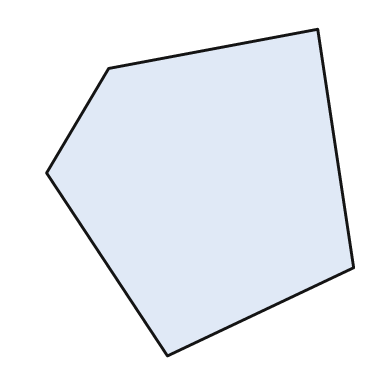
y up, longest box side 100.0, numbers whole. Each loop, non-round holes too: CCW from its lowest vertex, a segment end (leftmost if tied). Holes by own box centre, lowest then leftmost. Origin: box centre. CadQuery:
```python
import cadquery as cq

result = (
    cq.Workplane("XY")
    .moveTo(-10.0, -50.0)
    .lineTo(47.0, -23.0)
    .lineTo(36.0, 50.0)
    .lineTo(-28.0, 38.0)
    .lineTo(-47.0, 6.0)
    .close()
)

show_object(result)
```